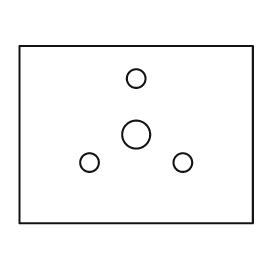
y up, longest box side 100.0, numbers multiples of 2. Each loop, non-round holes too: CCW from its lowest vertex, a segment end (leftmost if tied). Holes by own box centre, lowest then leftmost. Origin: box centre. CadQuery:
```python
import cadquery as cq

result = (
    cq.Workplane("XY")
    .moveTo(-50.0, -38.0)
    .lineTo(50.0, -38.0)
    .lineTo(50.0, 38.0)
    .lineTo(-50.0, 38.0)
    .close()
    .moveTo(-20.0, -12.0)
    .circle(4.0)
    .moveTo(20.0, -12.0)
    .circle(4.0)
    .moveTo(0.0, 0.0)
    .circle(6.0)
    .moveTo(0.0, 24.0)
    .circle(4.0)
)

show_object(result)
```